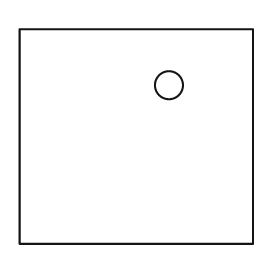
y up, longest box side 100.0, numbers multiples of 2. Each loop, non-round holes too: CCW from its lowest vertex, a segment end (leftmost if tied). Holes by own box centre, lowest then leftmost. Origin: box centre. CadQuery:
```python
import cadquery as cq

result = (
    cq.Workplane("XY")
    .moveTo(-50.0, -46.0)
    .lineTo(50.0, -46.0)
    .lineTo(50.0, 46.0)
    .lineTo(-50.0, 46.0)
    .close()
    .moveTo(14.0, 22.0)
    .circle(6.0)
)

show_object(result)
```